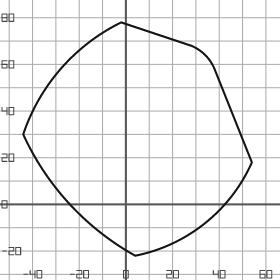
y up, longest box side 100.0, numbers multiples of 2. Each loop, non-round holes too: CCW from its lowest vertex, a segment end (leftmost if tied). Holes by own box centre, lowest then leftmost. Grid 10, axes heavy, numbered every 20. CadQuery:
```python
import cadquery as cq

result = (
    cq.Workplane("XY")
    .moveTo(4.0, -22.0)
    .threePointArc((34.0, -8.0), (54.0, 18.0))
    .lineTo(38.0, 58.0)
    .threePointArc((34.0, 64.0), (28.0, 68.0))
    .lineTo(-2.0, 78.0)
    .threePointArc((-28.0, 58.0), (-44.0, 30.0))
    .threePointArc((-24.0, 0.0), (4.0, -22.0))
    .close()
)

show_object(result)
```